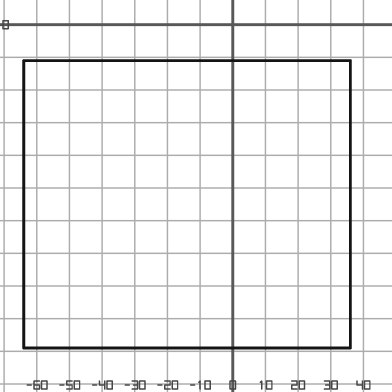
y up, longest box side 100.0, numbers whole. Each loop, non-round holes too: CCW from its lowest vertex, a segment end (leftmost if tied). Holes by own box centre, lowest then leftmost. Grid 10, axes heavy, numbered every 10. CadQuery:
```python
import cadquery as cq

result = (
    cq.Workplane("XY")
    .moveTo(-64.0, -99.0)
    .lineTo(36.0, -99.0)
    .lineTo(36.0, -11.0)
    .lineTo(-64.0, -11.0)
    .close()
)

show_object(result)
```